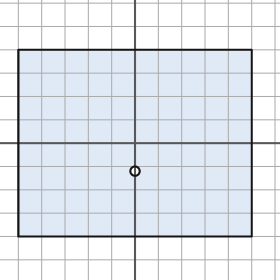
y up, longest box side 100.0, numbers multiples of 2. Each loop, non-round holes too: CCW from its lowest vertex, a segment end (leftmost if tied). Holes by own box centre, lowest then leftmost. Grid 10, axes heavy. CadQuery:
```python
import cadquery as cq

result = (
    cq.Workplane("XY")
    .moveTo(-50.0, -40.0)
    .lineTo(50.0, -40.0)
    .lineTo(50.0, 40.0)
    .lineTo(-50.0, 40.0)
    .close()
    .moveTo(0.0, -12.0)
    .circle(2.0)
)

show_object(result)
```